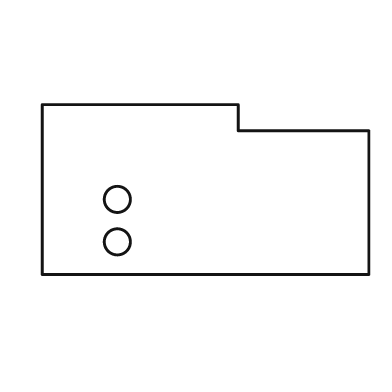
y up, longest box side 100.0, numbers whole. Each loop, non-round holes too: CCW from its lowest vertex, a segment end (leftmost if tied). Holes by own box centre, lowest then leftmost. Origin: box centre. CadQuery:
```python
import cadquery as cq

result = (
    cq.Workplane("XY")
    .moveTo(-50.0, -26.0)
    .lineTo(50.0, -26.0)
    .lineTo(50.0, 18.0)
    .lineTo(10.0, 18.0)
    .lineTo(10.0, 26.0)
    .lineTo(-50.0, 26.0)
    .close()
    .moveTo(-27.0, -16.0)
    .circle(4.0)
    .moveTo(-27.0, -3.0)
    .circle(4.0)
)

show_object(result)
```